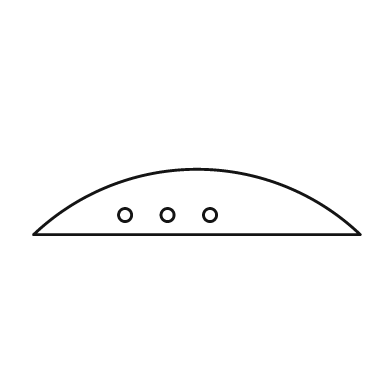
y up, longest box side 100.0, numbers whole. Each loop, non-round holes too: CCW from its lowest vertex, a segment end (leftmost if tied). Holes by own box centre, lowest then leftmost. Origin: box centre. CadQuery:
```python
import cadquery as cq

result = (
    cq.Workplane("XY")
    .moveTo(-50.0, -10.0)
    .lineTo(50.0, -10.0)
    .threePointArc((0.0, 10.0), (-50.0, -10.0))
    .close()
    .moveTo(-22.0, -4.0)
    .circle(2.0)
    .moveTo(-9.0, -4.0)
    .circle(2.0)
    .moveTo(4.0, -4.0)
    .circle(2.0)
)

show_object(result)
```